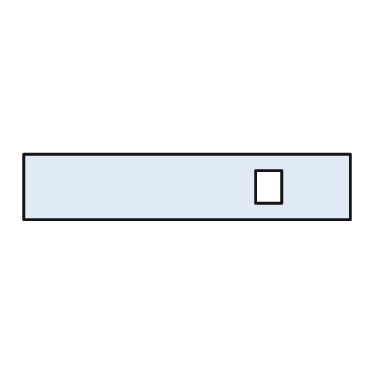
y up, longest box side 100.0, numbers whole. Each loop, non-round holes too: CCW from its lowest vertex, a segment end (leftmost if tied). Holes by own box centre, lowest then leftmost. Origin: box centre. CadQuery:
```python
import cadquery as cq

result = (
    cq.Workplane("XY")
    .moveTo(-50.0, -10.0)
    .lineTo(50.0, -10.0)
    .lineTo(50.0, 10.0)
    .lineTo(-50.0, 10.0)
    .close()
    .moveTo(21.0, -5.0)
    .lineTo(29.0, -5.0)
    .lineTo(29.0, 5.0)
    .lineTo(21.0, 5.0)
    .close()
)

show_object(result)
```